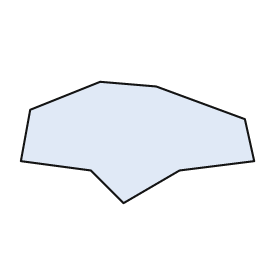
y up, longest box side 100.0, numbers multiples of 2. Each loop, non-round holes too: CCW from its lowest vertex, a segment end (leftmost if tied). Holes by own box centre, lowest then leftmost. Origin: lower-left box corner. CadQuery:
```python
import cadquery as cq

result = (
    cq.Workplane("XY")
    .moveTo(44.0, 0.0)
    .lineTo(68.0, 14.0)
    .lineTo(100.0, 18.0)
    .lineTo(96.0, 36.0)
    .lineTo(58.0, 50.0)
    .lineTo(34.0, 52.0)
    .lineTo(4.0, 40.0)
    .lineTo(0.0, 18.0)
    .lineTo(30.0, 14.0)
    .close()
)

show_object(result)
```